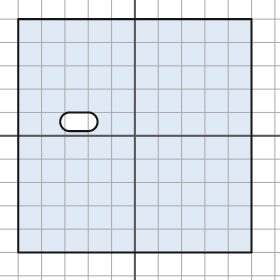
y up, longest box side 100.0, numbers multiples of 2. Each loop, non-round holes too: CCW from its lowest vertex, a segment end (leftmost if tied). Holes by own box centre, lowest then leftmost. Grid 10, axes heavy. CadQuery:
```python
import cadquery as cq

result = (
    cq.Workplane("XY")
    .moveTo(-50.0, -50.0)
    .lineTo(50.0, -50.0)
    .lineTo(50.0, 50.0)
    .lineTo(-50.0, 50.0)
    .close()
    .moveTo(-28.0, 2.0)
    .lineTo(-20.0, 2.0)
    .threePointArc((-16.0, 6.0), (-20.0, 10.0))
    .lineTo(-28.0, 10.0)
    .threePointArc((-32.0, 6.0), (-28.0, 2.0))
    .close()
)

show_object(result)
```